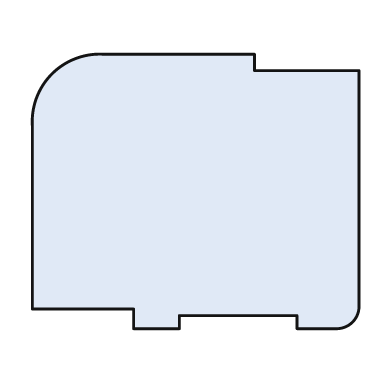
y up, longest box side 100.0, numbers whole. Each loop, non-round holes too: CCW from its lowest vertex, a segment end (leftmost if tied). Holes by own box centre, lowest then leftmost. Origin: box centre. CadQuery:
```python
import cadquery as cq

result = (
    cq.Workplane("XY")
    .moveTo(-19.0, -42.0)
    .lineTo(-5.0, -42.0)
    .lineTo(-5.0, -38.0)
    .lineTo(31.0, -38.0)
    .lineTo(31.0, -42.0)
    .lineTo(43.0, -42.0)
    .threePointArc((48.0, -40.0), (50.0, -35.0))
    .lineTo(50.0, 37.0)
    .lineTo(18.0, 37.0)
    .lineTo(18.0, 42.0)
    .lineTo(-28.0, 42.0)
    .threePointArc((-44.0, 36.0), (-50.0, 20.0))
    .lineTo(-50.0, -36.0)
    .lineTo(-19.0, -36.0)
    .close()
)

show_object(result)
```